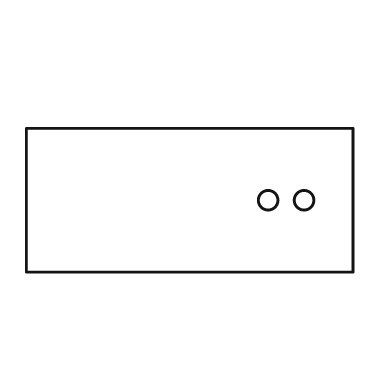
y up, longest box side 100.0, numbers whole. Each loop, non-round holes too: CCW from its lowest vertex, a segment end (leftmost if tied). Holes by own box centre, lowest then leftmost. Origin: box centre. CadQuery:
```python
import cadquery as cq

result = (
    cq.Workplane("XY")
    .moveTo(-50.0, -22.0)
    .lineTo(50.0, -22.0)
    .lineTo(50.0, 22.0)
    .lineTo(-50.0, 22.0)
    .close()
    .moveTo(24.0, 0.0)
    .circle(3.0)
    .moveTo(35.0, 0.0)
    .circle(3.0)
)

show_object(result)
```